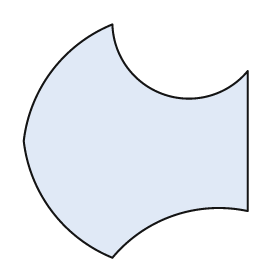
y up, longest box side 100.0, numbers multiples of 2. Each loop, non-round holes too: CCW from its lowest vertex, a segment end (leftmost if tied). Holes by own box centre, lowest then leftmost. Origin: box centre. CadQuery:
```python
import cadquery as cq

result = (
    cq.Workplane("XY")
    .moveTo(-10.0, -50.0)
    .threePointArc((16.0, -32.0), (48.0, -30.0))
    .lineTo(48.0, 30.0)
    .threePointArc((12.0, 20.0), (-10.0, 50.0))
    .threePointArc((-36.0, 30.0), (-48.0, 0.0))
    .threePointArc((-36.0, -30.0), (-10.0, -50.0))
    .close()
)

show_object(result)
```